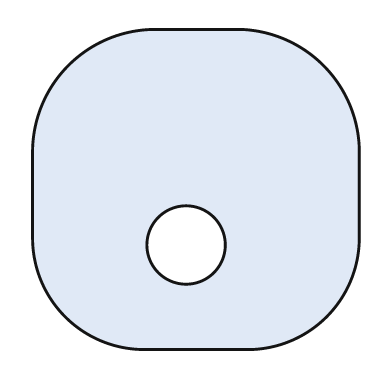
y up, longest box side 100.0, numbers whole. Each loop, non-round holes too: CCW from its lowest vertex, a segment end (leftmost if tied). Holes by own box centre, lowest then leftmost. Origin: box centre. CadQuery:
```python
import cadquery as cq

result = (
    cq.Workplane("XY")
    .moveTo(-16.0, -49.0)
    .lineTo(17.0, -49.0)
    .threePointArc((40.0, -39.0), (50.0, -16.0))
    .lineTo(50.0, 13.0)
    .threePointArc((39.0, 38.0), (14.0, 49.0))
    .lineTo(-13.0, 49.0)
    .threePointArc((-39.0, 38.0), (-50.0, 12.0))
    .lineTo(-50.0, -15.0)
    .threePointArc((-40.0, -39.0), (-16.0, -49.0))
    .close()
    .moveTo(-3.0, -17.0)
    .circle(12.0)
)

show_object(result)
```